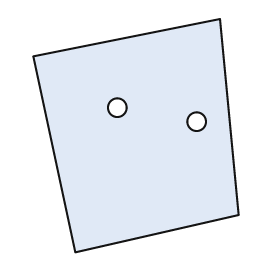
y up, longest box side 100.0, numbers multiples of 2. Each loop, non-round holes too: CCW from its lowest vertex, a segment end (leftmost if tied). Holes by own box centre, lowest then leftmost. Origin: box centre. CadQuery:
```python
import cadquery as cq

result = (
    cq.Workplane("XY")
    .moveTo(-26.0, -50.0)
    .lineTo(44.0, -34.0)
    .lineTo(36.0, 50.0)
    .lineTo(-44.0, 34.0)
    .close()
    .moveTo(26.0, 6.0)
    .circle(4.0)
    .moveTo(-8.0, 12.0)
    .circle(4.0)
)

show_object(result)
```